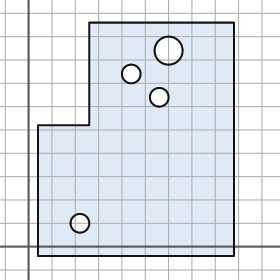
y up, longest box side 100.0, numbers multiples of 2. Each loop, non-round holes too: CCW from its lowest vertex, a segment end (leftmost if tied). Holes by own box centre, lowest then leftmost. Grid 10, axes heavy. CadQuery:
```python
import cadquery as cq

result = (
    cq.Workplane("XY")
    .moveTo(4.0, -4.0)
    .lineTo(88.0, -4.0)
    .lineTo(88.0, 96.0)
    .lineTo(26.0, 96.0)
    .lineTo(26.0, 52.0)
    .lineTo(4.0, 52.0)
    .close()
    .moveTo(22.0, 10.0)
    .circle(4.0)
    .moveTo(56.0, 64.0)
    .circle(4.0)
    .moveTo(44.0, 74.0)
    .circle(4.0)
    .moveTo(60.0, 84.0)
    .circle(6.0)
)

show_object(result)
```